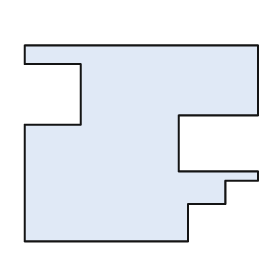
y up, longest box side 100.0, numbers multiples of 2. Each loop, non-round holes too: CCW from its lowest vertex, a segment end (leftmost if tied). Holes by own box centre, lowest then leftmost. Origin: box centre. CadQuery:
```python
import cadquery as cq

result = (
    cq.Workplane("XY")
    .moveTo(-50.0, -42.0)
    .lineTo(20.0, -42.0)
    .lineTo(20.0, -26.0)
    .lineTo(36.0, -26.0)
    .lineTo(36.0, -16.0)
    .lineTo(50.0, -16.0)
    .lineTo(50.0, -12.0)
    .lineTo(16.0, -12.0)
    .lineTo(16.0, 12.0)
    .lineTo(50.0, 12.0)
    .lineTo(50.0, 42.0)
    .lineTo(-50.0, 42.0)
    .lineTo(-50.0, 34.0)
    .lineTo(-26.0, 34.0)
    .lineTo(-26.0, 8.0)
    .lineTo(-50.0, 8.0)
    .close()
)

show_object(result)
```